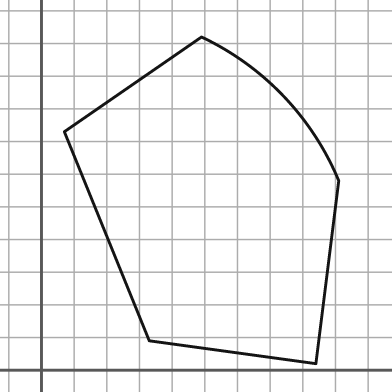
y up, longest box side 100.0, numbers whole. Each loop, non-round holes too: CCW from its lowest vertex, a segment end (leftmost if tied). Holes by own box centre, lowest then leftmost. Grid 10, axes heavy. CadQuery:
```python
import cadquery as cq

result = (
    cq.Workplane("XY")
    .moveTo(84.0, 2.0)
    .lineTo(91.0, 58.0)
    .threePointArc((74.0, 84.0), (49.0, 102.0))
    .lineTo(7.0, 73.0)
    .lineTo(33.0, 9.0)
    .close()
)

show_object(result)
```